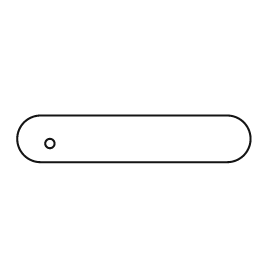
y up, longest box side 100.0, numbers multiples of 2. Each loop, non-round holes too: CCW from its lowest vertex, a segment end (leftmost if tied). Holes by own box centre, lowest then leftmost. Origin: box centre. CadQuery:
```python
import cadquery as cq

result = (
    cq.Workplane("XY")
    .moveTo(-40.0, -10.0)
    .lineTo(40.0, -10.0)
    .threePointArc((50.0, 0.0), (40.0, 10.0))
    .lineTo(-40.0, 10.0)
    .threePointArc((-50.0, 0.0), (-40.0, -10.0))
    .close()
    .moveTo(-36.0, -2.0)
    .circle(2.0)
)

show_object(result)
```